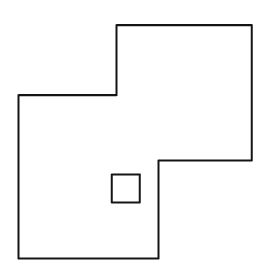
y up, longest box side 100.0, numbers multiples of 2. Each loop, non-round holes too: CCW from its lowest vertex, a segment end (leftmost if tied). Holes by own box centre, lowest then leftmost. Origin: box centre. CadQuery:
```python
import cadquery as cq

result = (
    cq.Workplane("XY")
    .moveTo(-50.0, -50.0)
    .lineTo(10.0, -50.0)
    .lineTo(10.0, -8.0)
    .lineTo(50.0, -8.0)
    .lineTo(50.0, 50.0)
    .lineTo(-8.0, 50.0)
    .lineTo(-8.0, 20.0)
    .lineTo(-50.0, 20.0)
    .close()
    .moveTo(-10.0, -26.0)
    .lineTo(2.0, -26.0)
    .lineTo(2.0, -14.0)
    .lineTo(-10.0, -14.0)
    .close()
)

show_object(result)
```